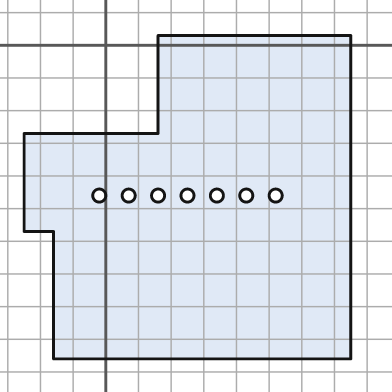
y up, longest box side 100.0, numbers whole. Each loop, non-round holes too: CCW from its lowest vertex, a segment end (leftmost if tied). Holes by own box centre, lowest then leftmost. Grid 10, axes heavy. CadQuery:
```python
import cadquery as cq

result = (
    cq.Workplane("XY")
    .moveTo(-16.0, -96.0)
    .lineTo(75.0, -96.0)
    .lineTo(75.0, 3.0)
    .lineTo(16.0, 3.0)
    .lineTo(16.0, -27.0)
    .lineTo(-25.0, -27.0)
    .lineTo(-25.0, -57.0)
    .lineTo(-16.0, -57.0)
    .close()
    .moveTo(-2.0, -46.0)
    .circle(2.0)
    .moveTo(7.0, -46.0)
    .circle(2.0)
    .moveTo(16.0, -46.0)
    .circle(2.0)
    .moveTo(25.0, -46.0)
    .circle(2.0)
    .moveTo(34.0, -46.0)
    .circle(2.0)
    .moveTo(43.0, -46.0)
    .circle(2.0)
    .moveTo(52.0, -46.0)
    .circle(2.0)
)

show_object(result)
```